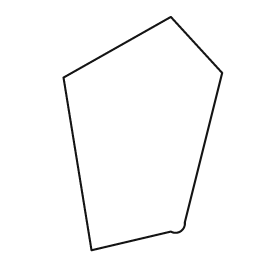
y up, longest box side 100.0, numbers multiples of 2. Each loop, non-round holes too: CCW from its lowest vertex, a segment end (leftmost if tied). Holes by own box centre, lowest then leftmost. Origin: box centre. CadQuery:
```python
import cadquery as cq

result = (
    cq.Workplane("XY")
    .moveTo(-22.0, -50.0)
    .lineTo(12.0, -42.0)
    .threePointArc((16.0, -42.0), (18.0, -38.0))
    .lineTo(34.0, 26.0)
    .lineTo(12.0, 50.0)
    .lineTo(-34.0, 24.0)
    .close()
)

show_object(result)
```